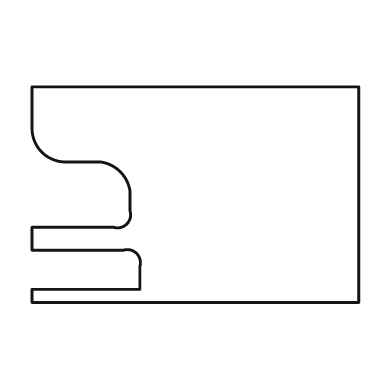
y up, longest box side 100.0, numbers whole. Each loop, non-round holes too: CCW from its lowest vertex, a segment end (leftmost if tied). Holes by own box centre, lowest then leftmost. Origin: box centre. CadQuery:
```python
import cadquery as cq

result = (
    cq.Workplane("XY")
    .moveTo(-50.0, -33.0)
    .lineTo(50.0, -33.0)
    .lineTo(50.0, 33.0)
    .lineTo(-50.0, 33.0)
    .lineTo(-50.0, 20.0)
    .threePointArc((-47.0, 13.0), (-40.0, 10.0))
    .lineTo(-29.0, 10.0)
    .threePointArc((-23.0, 7.0), (-20.0, 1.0))
    .lineTo(-20.0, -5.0)
    .threePointArc((-21.0, -9.0), (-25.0, -10.0))
    .lineTo(-50.0, -10.0)
    .lineTo(-50.0, -17.0)
    .lineTo(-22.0, -17.0)
    .threePointArc((-18.0, -18.0), (-17.0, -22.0))
    .lineTo(-17.0, -29.0)
    .lineTo(-50.0, -29.0)
    .close()
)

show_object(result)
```